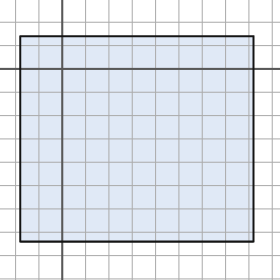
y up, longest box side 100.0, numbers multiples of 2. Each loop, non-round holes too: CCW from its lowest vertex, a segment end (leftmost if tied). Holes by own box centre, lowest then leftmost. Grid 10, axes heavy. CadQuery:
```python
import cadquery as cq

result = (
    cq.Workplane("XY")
    .moveTo(-18.0, -74.0)
    .lineTo(82.0, -74.0)
    .lineTo(82.0, 14.0)
    .lineTo(-18.0, 14.0)
    .close()
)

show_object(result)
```